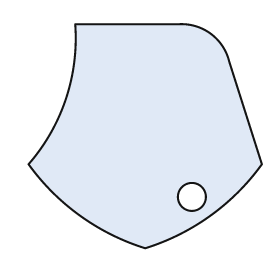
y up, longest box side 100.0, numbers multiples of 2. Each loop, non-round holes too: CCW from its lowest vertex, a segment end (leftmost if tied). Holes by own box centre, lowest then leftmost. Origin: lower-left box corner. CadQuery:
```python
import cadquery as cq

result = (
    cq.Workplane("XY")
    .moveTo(50.0, 0.0)
    .threePointArc((78.0, 14.0), (100.0, 36.0))
    .lineTo(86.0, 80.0)
    .threePointArc((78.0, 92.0), (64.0, 96.0))
    .lineTo(20.0, 96.0)
    .threePointArc((16.0, 64.0), (0.0, 36.0))
    .threePointArc((22.0, 14.0), (50.0, 0.0))
    .close()
    .moveTo(70.0, 22.0)
    .circle(6.0)
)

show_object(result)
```